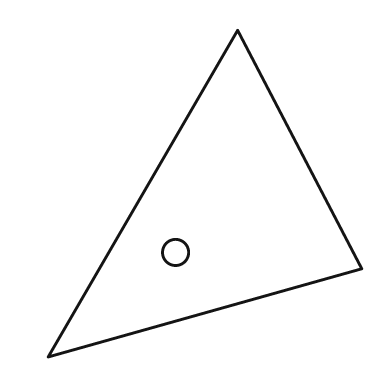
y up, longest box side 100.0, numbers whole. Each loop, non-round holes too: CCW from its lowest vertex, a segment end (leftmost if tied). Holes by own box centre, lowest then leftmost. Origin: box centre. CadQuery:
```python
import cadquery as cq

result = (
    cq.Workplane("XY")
    .moveTo(-48.0, -50.0)
    .lineTo(48.0, -23.0)
    .lineTo(10.0, 50.0)
    .close()
    .moveTo(-9.0, -18.0)
    .circle(4.0)
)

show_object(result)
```